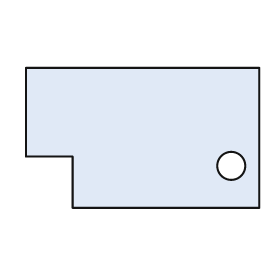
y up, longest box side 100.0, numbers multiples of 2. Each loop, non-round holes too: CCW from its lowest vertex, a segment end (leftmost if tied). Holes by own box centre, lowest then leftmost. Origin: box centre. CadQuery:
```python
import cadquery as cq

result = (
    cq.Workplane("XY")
    .moveTo(-30.0, -30.0)
    .lineTo(50.0, -30.0)
    .lineTo(50.0, 30.0)
    .lineTo(-50.0, 30.0)
    .lineTo(-50.0, -8.0)
    .lineTo(-30.0, -8.0)
    .close()
    .moveTo(38.0, -12.0)
    .circle(6.0)
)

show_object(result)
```